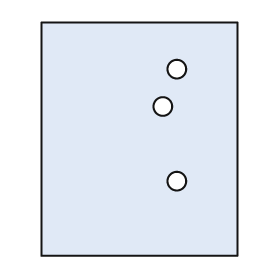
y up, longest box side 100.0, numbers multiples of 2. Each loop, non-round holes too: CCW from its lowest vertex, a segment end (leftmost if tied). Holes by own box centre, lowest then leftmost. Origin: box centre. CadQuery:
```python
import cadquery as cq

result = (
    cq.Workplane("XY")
    .moveTo(-42.0, -50.0)
    .lineTo(42.0, -50.0)
    .lineTo(42.0, 50.0)
    .lineTo(-42.0, 50.0)
    .close()
    .moveTo(16.0, -18.0)
    .circle(4.0)
    .moveTo(10.0, 14.0)
    .circle(4.0)
    .moveTo(16.0, 30.0)
    .circle(4.0)
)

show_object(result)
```